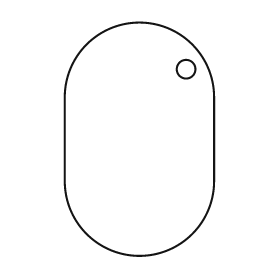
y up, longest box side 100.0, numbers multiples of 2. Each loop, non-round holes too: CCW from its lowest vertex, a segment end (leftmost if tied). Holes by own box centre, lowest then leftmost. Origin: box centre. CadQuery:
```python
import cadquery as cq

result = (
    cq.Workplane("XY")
    .moveTo(-32.0, -18.0)
    .threePointArc((0.0, -50.0), (32.0, -18.0))
    .lineTo(32.0, 18.0)
    .threePointArc((0.0, 50.0), (-32.0, 18.0))
    .close()
    .moveTo(20.0, 30.0)
    .circle(4.0)
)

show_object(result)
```